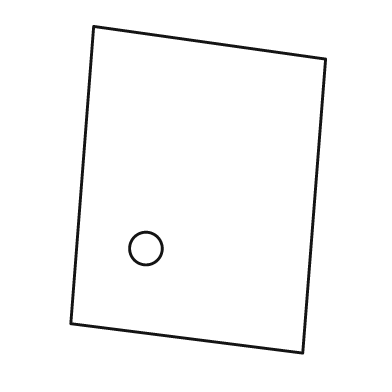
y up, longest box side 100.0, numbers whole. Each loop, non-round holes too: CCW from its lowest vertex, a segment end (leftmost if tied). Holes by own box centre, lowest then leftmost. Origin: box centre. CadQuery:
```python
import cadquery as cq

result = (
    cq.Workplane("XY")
    .moveTo(32.0, -50.0)
    .lineTo(39.0, 40.0)
    .lineTo(-32.0, 50.0)
    .lineTo(-39.0, -41.0)
    .close()
    .moveTo(-16.0, -18.0)
    .circle(5.0)
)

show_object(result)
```